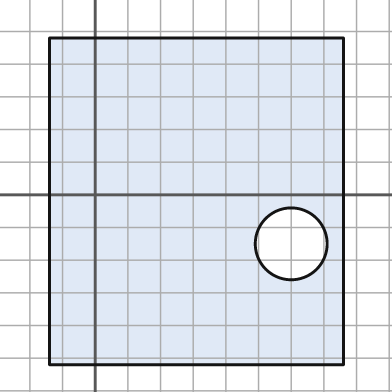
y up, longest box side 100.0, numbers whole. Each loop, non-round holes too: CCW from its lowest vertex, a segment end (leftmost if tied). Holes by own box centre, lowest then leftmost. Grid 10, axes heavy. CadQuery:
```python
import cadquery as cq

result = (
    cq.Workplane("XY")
    .moveTo(-14.0, -52.0)
    .lineTo(76.0, -52.0)
    .lineTo(76.0, 48.0)
    .lineTo(-14.0, 48.0)
    .close()
    .moveTo(60.0, -15.0)
    .circle(11.0)
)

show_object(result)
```